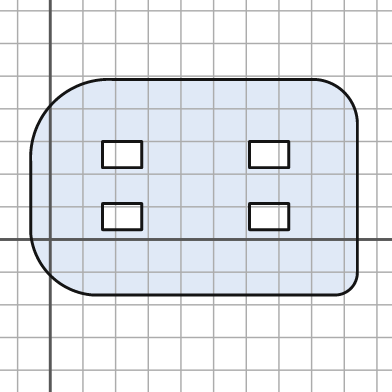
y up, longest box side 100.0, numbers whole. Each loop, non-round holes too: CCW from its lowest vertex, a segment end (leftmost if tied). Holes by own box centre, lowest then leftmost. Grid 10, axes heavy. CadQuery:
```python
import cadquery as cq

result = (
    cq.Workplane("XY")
    .moveTo(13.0, -17.0)
    .lineTo(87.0, -17.0)
    .threePointArc((92.0, -15.0), (94.0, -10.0))
    .lineTo(94.0, 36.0)
    .threePointArc((90.0, 45.0), (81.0, 49.0))
    .lineTo(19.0, 49.0)
    .threePointArc((1.0, 42.0), (-6.0, 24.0))
    .lineTo(-6.0, 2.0)
    .threePointArc((0.0, -11.0), (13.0, -17.0))
    .close()
    .moveTo(16.0, 3.0)
    .lineTo(28.0, 3.0)
    .lineTo(28.0, 11.0)
    .lineTo(16.0, 11.0)
    .close()
    .moveTo(61.0, 3.0)
    .lineTo(73.0, 3.0)
    .lineTo(73.0, 11.0)
    .lineTo(61.0, 11.0)
    .close()
    .moveTo(16.0, 22.0)
    .lineTo(28.0, 22.0)
    .lineTo(28.0, 30.0)
    .lineTo(16.0, 30.0)
    .close()
    .moveTo(61.0, 22.0)
    .lineTo(73.0, 22.0)
    .lineTo(73.0, 30.0)
    .lineTo(61.0, 30.0)
    .close()
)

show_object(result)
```